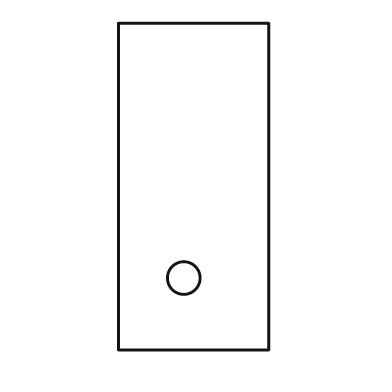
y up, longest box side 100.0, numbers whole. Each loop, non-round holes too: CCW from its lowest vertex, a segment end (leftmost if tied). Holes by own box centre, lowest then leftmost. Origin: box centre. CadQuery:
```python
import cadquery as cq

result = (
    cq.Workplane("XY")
    .moveTo(-23.0, -50.0)
    .lineTo(23.0, -50.0)
    .lineTo(23.0, 50.0)
    .lineTo(-23.0, 50.0)
    .close()
    .moveTo(-3.0, -28.0)
    .circle(5.0)
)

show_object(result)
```